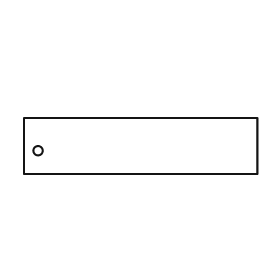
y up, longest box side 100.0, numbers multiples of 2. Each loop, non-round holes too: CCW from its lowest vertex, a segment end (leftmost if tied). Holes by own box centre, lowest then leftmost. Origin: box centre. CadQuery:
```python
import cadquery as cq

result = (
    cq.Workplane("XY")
    .moveTo(-50.0, -12.0)
    .lineTo(50.0, -12.0)
    .lineTo(50.0, 12.0)
    .lineTo(-50.0, 12.0)
    .close()
    .moveTo(-44.0, -2.0)
    .circle(2.0)
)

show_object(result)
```